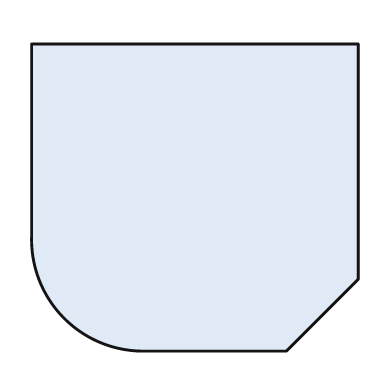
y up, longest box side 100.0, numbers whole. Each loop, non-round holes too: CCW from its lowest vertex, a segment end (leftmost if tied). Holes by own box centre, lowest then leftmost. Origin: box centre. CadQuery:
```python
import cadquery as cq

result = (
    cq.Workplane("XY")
    .moveTo(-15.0, -47.0)
    .lineTo(28.0, -47.0)
    .lineTo(50.0, -25.0)
    .lineTo(50.0, 47.0)
    .lineTo(-50.0, 47.0)
    .lineTo(-50.0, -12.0)
    .threePointArc((-40.0, -37.0), (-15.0, -47.0))
    .close()
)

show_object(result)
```